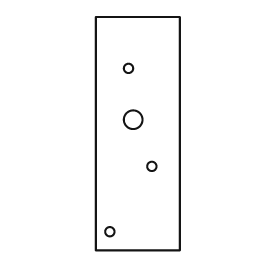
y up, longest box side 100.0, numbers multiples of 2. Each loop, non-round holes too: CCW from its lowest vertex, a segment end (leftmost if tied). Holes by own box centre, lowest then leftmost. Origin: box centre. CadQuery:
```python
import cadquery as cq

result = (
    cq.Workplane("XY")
    .moveTo(-18.0, -50.0)
    .lineTo(18.0, -50.0)
    .lineTo(18.0, 50.0)
    .lineTo(-18.0, 50.0)
    .close()
    .moveTo(-12.0, -42.0)
    .circle(2.0)
    .moveTo(6.0, -14.0)
    .circle(2.0)
    .moveTo(-2.0, 6.0)
    .circle(4.0)
    .moveTo(-4.0, 28.0)
    .circle(2.0)
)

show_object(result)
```